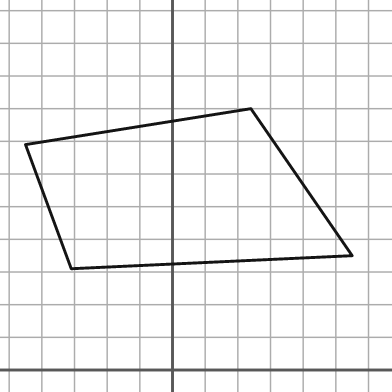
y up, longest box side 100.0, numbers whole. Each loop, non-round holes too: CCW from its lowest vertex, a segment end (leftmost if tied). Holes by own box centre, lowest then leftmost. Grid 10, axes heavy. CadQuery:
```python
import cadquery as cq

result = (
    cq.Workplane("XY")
    .moveTo(-31.0, 31.0)
    .lineTo(55.0, 35.0)
    .lineTo(24.0, 80.0)
    .lineTo(-45.0, 69.0)
    .close()
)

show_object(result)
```